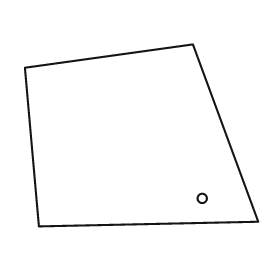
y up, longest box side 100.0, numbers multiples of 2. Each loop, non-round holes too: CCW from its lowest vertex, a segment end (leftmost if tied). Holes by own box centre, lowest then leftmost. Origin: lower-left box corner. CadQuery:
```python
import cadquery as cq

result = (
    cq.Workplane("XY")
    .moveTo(6.0, 0.0)
    .lineTo(100.0, 2.0)
    .lineTo(72.0, 78.0)
    .lineTo(0.0, 68.0)
    .close()
    .moveTo(76.0, 12.0)
    .circle(2.0)
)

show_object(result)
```